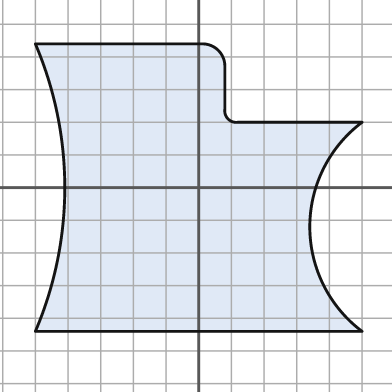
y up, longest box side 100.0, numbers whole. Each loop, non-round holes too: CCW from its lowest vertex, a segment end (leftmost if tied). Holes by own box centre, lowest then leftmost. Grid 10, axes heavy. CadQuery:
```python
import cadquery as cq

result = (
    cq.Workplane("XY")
    .moveTo(-50.0, -44.0)
    .lineTo(50.0, -44.0)
    .threePointArc((34.0, -12.0), (50.0, 20.0))
    .lineTo(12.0, 20.0)
    .threePointArc((9.0, 21.0), (8.0, 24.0))
    .lineTo(8.0, 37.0)
    .threePointArc((6.0, 42.0), (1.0, 44.0))
    .lineTo(-50.0, 44.0)
    .threePointArc((-41.0, 0.0), (-50.0, -44.0))
    .close()
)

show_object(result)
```